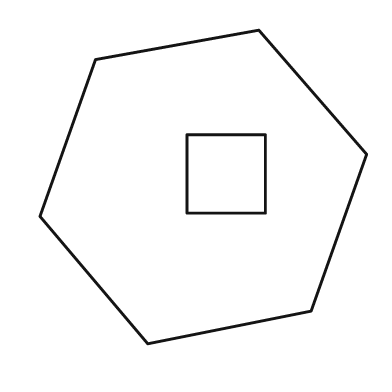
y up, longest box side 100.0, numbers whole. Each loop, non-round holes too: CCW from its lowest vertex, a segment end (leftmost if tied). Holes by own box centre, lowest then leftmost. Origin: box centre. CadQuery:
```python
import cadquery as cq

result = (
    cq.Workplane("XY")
    .moveTo(-17.0, -48.0)
    .lineTo(33.0, -38.0)
    .lineTo(50.0, 10.0)
    .lineTo(17.0, 48.0)
    .lineTo(-33.0, 39.0)
    .lineTo(-50.0, -9.0)
    .close()
    .moveTo(-5.0, -8.0)
    .lineTo(19.0, -8.0)
    .lineTo(19.0, 16.0)
    .lineTo(-5.0, 16.0)
    .close()
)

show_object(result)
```